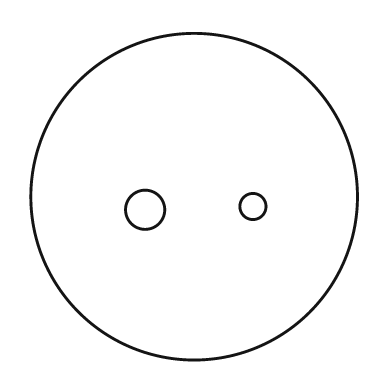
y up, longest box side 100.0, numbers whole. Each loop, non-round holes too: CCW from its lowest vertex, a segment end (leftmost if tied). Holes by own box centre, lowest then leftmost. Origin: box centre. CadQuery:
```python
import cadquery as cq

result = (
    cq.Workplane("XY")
    .moveTo(0.0, 0.0)
    .circle(50.0)
    .moveTo(-15.0, -4.0)
    .circle(6.0)
    .moveTo(18.0, -3.0)
    .circle(4.0)
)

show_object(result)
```